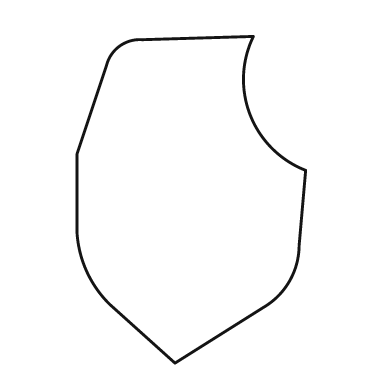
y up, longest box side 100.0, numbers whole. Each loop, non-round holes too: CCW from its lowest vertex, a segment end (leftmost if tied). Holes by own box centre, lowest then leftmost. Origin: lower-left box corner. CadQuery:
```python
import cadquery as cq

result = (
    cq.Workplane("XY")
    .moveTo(30.0, 0.0)
    .lineTo(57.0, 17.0)
    .threePointArc((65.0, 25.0), (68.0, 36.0))
    .lineTo(70.0, 59.0)
    .threePointArc((53.0, 76.0), (54.0, 100.0))
    .lineTo(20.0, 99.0)
    .threePointArc((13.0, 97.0), (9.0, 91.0))
    .lineTo(0.0, 64.0)
    .lineTo(0.0, 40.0)
    .threePointArc((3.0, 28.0), (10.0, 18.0))
    .close()
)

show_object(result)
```